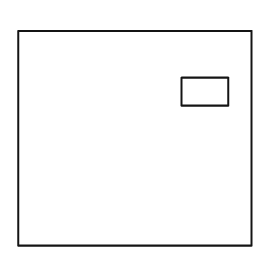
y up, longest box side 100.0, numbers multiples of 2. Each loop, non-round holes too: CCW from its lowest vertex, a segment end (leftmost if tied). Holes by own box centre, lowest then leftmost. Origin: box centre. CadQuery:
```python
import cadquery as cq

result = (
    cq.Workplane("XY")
    .moveTo(-50.0, -46.0)
    .lineTo(50.0, -46.0)
    .lineTo(50.0, 46.0)
    .lineTo(-50.0, 46.0)
    .close()
    .moveTo(20.0, 14.0)
    .lineTo(40.0, 14.0)
    .lineTo(40.0, 26.0)
    .lineTo(20.0, 26.0)
    .close()
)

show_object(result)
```